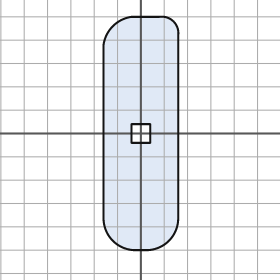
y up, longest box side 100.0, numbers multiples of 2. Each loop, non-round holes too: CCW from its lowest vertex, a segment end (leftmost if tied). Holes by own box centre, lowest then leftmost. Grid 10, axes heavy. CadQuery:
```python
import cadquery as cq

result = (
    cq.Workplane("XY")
    .moveTo(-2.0, -50.0)
    .lineTo(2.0, -50.0)
    .threePointArc((12.0, -46.0), (16.0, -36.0))
    .lineTo(16.0, 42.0)
    .threePointArc((14.0, 48.0), (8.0, 50.0))
    .lineTo(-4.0, 50.0)
    .threePointArc((-12.0, 46.0), (-16.0, 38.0))
    .lineTo(-16.0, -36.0)
    .threePointArc((-12.0, -46.0), (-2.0, -50.0))
    .close()
    .moveTo(-4.0, -4.0)
    .lineTo(4.0, -4.0)
    .lineTo(4.0, 4.0)
    .lineTo(-4.0, 4.0)
    .close()
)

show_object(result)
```